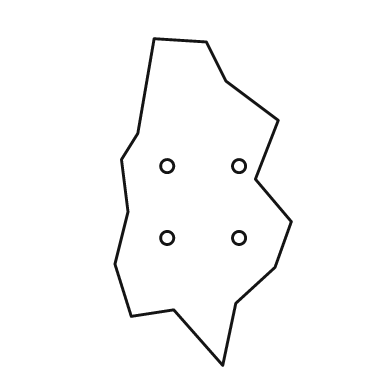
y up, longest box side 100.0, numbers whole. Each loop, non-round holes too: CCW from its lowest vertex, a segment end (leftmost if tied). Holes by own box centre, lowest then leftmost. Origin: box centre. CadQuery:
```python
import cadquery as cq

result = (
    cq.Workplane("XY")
    .moveTo(6.0, -50.0)
    .lineTo(10.0, -31.0)
    .lineTo(22.0, -20.0)
    .lineTo(27.0, -6.0)
    .lineTo(16.0, 7.0)
    .lineTo(23.0, 25.0)
    .lineTo(7.0, 37.0)
    .lineTo(1.0, 49.0)
    .lineTo(-15.0, 50.0)
    .lineTo(-20.0, 21.0)
    .lineTo(-25.0, 13.0)
    .lineTo(-23.0, -3.0)
    .lineTo(-27.0, -19.0)
    .lineTo(-22.0, -35.0)
    .lineTo(-9.0, -33.0)
    .close()
    .moveTo(-11.0, -11.0)
    .circle(2.0)
    .moveTo(11.0, -11.0)
    .circle(2.0)
    .moveTo(-11.0, 11.0)
    .circle(2.0)
    .moveTo(11.0, 11.0)
    .circle(2.0)
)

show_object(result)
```